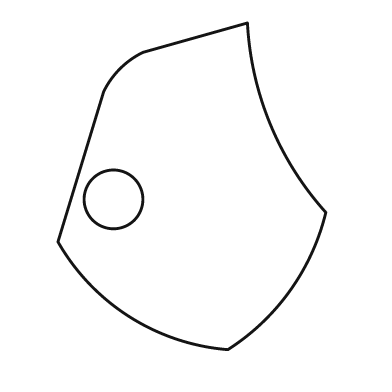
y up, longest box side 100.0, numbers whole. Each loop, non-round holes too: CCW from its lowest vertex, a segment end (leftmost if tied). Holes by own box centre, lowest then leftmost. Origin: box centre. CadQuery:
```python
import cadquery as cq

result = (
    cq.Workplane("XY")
    .moveTo(11.0, -50.0)
    .threePointArc((30.0, -32.0), (41.0, -8.0))
    .threePointArc((24.0, 19.0), (17.0, 50.0))
    .lineTo(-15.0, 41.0)
    .threePointArc((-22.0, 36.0), (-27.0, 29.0))
    .lineTo(-41.0, -17.0)
    .threePointArc((-19.0, -40.0), (11.0, -50.0))
    .close()
    .moveTo(-24.0, -4.0)
    .circle(9.0)
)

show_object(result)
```